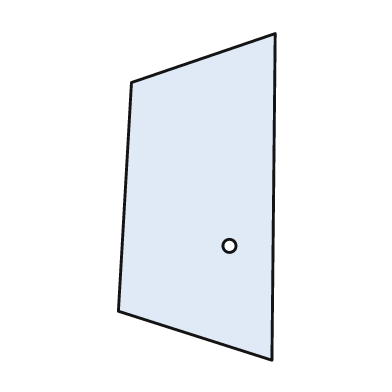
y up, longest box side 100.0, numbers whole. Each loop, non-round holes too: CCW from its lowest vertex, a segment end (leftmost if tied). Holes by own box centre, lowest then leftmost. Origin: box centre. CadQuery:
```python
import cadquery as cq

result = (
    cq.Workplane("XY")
    .moveTo(23.0, -50.0)
    .lineTo(24.0, 50.0)
    .lineTo(-20.0, 35.0)
    .lineTo(-24.0, -35.0)
    .close()
    .moveTo(10.0, -15.0)
    .circle(2.0)
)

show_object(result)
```